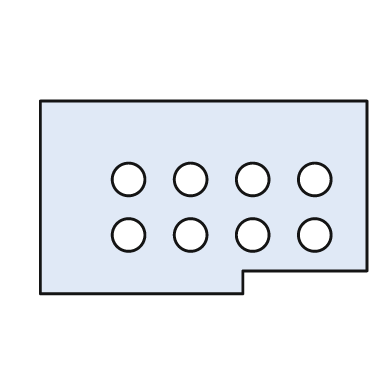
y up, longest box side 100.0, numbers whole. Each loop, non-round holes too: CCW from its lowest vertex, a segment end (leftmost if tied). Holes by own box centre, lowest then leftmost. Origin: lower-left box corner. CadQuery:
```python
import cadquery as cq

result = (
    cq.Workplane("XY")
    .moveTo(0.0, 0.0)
    .lineTo(62.0, 0.0)
    .lineTo(62.0, 7.0)
    .lineTo(100.0, 7.0)
    .lineTo(100.0, 59.0)
    .lineTo(0.0, 59.0)
    .close()
    .moveTo(27.0, 18.0)
    .circle(5.0)
    .moveTo(46.0, 18.0)
    .circle(5.0)
    .moveTo(65.0, 18.0)
    .circle(5.0)
    .moveTo(84.0, 18.0)
    .circle(5.0)
    .moveTo(27.0, 35.0)
    .circle(5.0)
    .moveTo(46.0, 35.0)
    .circle(5.0)
    .moveTo(65.0, 35.0)
    .circle(5.0)
    .moveTo(84.0, 35.0)
    .circle(5.0)
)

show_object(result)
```